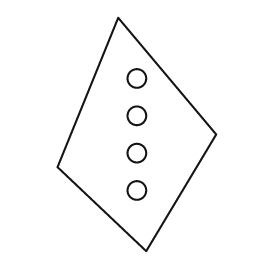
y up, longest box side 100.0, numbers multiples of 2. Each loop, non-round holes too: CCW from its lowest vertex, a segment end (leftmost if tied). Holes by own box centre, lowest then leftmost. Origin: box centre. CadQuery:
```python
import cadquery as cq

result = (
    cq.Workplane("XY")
    .moveTo(4.0, -50.0)
    .lineTo(34.0, 0.0)
    .lineTo(-8.0, 50.0)
    .lineTo(-34.0, -14.0)
    .close()
    .moveTo(0.0, -24.0)
    .circle(4.0)
    .moveTo(0.0, -8.0)
    .circle(4.0)
    .moveTo(0.0, 8.0)
    .circle(4.0)
    .moveTo(0.0, 24.0)
    .circle(4.0)
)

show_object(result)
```